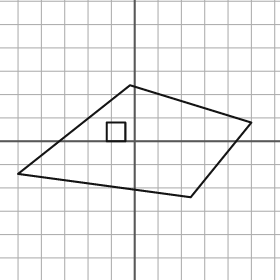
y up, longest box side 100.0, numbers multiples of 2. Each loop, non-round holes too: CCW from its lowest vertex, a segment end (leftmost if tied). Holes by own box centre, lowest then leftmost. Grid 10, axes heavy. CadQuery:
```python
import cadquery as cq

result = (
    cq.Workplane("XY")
    .moveTo(24.0, -24.0)
    .lineTo(50.0, 8.0)
    .lineTo(-2.0, 24.0)
    .lineTo(-50.0, -14.0)
    .close()
    .moveTo(-12.0, 0.0)
    .lineTo(-4.0, 0.0)
    .lineTo(-4.0, 8.0)
    .lineTo(-12.0, 8.0)
    .close()
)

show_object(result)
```